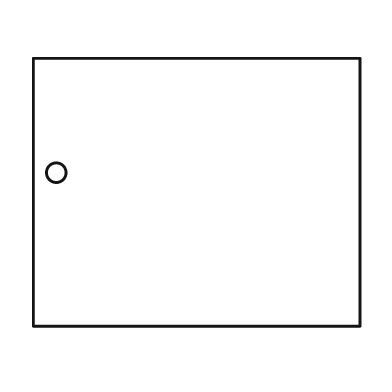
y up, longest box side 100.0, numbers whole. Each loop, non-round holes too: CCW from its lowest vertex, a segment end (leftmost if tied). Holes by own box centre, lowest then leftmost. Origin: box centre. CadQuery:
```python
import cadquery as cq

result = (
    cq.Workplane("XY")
    .moveTo(-50.0, -41.0)
    .lineTo(50.0, -41.0)
    .lineTo(50.0, 41.0)
    .lineTo(-50.0, 41.0)
    .close()
    .moveTo(-43.0, 6.0)
    .circle(3.0)
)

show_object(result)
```